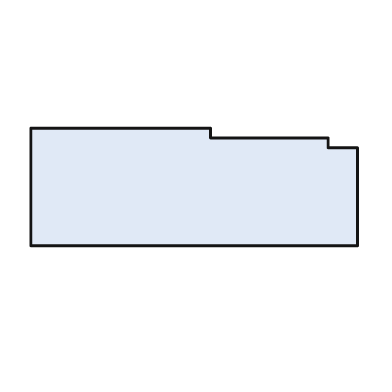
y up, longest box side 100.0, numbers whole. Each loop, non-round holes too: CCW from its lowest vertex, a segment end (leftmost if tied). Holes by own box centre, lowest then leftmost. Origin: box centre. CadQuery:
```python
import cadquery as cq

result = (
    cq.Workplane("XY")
    .moveTo(-50.0, -18.0)
    .lineTo(50.0, -18.0)
    .lineTo(50.0, 12.0)
    .lineTo(41.0, 12.0)
    .lineTo(41.0, 15.0)
    .lineTo(5.0, 15.0)
    .lineTo(5.0, 18.0)
    .lineTo(-50.0, 18.0)
    .close()
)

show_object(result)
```